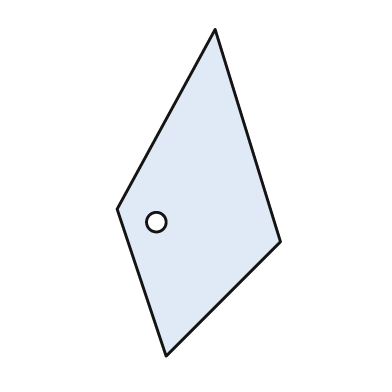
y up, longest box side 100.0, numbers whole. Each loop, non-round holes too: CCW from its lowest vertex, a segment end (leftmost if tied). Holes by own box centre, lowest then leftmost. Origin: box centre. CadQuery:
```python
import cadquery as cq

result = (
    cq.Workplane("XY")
    .moveTo(-10.0, -50.0)
    .lineTo(25.0, -15.0)
    .lineTo(5.0, 50.0)
    .lineTo(-25.0, -5.0)
    .close()
    .moveTo(-13.0, -9.0)
    .circle(3.0)
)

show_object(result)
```